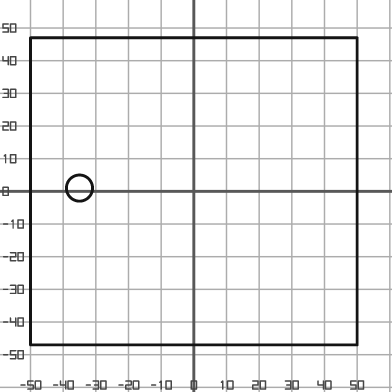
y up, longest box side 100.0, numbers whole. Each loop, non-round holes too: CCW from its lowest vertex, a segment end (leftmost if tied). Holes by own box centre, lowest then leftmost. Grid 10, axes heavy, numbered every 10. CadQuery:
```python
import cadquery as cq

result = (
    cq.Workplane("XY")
    .moveTo(-50.0, -47.0)
    .lineTo(50.0, -47.0)
    .lineTo(50.0, 47.0)
    .lineTo(-50.0, 47.0)
    .close()
    .moveTo(-35.0, 1.0)
    .circle(4.0)
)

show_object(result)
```